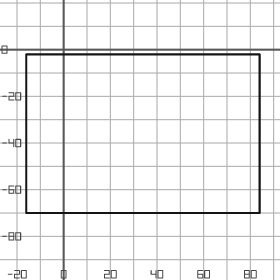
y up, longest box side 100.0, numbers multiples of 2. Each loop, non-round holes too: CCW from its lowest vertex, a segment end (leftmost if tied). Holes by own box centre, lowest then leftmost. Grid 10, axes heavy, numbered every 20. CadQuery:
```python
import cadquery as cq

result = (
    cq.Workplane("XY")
    .moveTo(-16.0, -70.0)
    .lineTo(84.0, -70.0)
    .lineTo(84.0, -2.0)
    .lineTo(-16.0, -2.0)
    .close()
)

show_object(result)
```